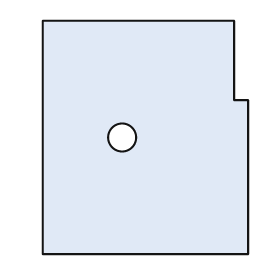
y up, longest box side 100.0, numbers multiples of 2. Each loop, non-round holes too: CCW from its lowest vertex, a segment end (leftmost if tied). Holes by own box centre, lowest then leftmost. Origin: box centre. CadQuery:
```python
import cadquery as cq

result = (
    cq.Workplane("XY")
    .moveTo(-44.0, -50.0)
    .lineTo(44.0, -50.0)
    .lineTo(44.0, 16.0)
    .lineTo(38.0, 16.0)
    .lineTo(38.0, 50.0)
    .lineTo(-44.0, 50.0)
    .close()
    .moveTo(-10.0, 0.0)
    .circle(6.0)
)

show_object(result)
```